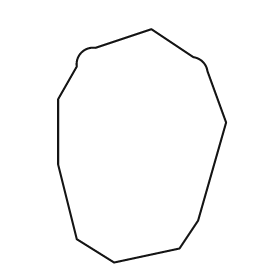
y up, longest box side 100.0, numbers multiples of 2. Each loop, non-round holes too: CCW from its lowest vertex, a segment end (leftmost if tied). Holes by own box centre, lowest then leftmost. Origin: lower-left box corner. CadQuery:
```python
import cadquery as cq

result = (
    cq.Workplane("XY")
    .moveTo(24.0, 0.0)
    .lineTo(52.0, 6.0)
    .lineTo(60.0, 18.0)
    .lineTo(72.0, 60.0)
    .lineTo(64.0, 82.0)
    .threePointArc((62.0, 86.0), (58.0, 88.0))
    .lineTo(40.0, 100.0)
    .lineTo(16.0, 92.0)
    .threePointArc((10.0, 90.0), (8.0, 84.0))
    .lineTo(0.0, 70.0)
    .lineTo(0.0, 42.0)
    .lineTo(8.0, 10.0)
    .close()
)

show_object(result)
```